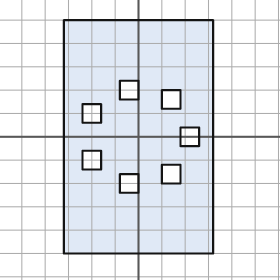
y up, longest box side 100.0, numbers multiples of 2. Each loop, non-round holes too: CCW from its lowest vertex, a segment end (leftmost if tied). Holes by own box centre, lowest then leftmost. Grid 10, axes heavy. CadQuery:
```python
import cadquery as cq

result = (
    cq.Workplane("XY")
    .moveTo(-32.0, -50.0)
    .lineTo(32.0, -50.0)
    .lineTo(32.0, 50.0)
    .lineTo(-32.0, 50.0)
    .close()
    .moveTo(-8.0, -24.0)
    .lineTo(0.0, -24.0)
    .lineTo(0.0, -16.0)
    .lineTo(-8.0, -16.0)
    .close()
    .moveTo(10.0, -20.0)
    .lineTo(18.0, -20.0)
    .lineTo(18.0, -12.0)
    .lineTo(10.0, -12.0)
    .close()
    .moveTo(-24.0, -14.0)
    .lineTo(-16.0, -14.0)
    .lineTo(-16.0, -6.0)
    .lineTo(-24.0, -6.0)
    .close()
    .moveTo(18.0, -4.0)
    .lineTo(26.0, -4.0)
    .lineTo(26.0, 4.0)
    .lineTo(18.0, 4.0)
    .close()
    .moveTo(-24.0, 6.0)
    .lineTo(-16.0, 6.0)
    .lineTo(-16.0, 14.0)
    .lineTo(-24.0, 14.0)
    .close()
    .moveTo(10.0, 12.0)
    .lineTo(18.0, 12.0)
    .lineTo(18.0, 20.0)
    .lineTo(10.0, 20.0)
    .close()
    .moveTo(-8.0, 16.0)
    .lineTo(0.0, 16.0)
    .lineTo(0.0, 24.0)
    .lineTo(-8.0, 24.0)
    .close()
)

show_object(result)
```